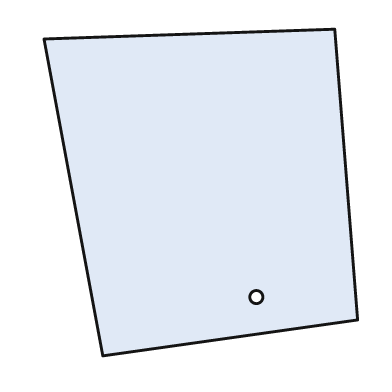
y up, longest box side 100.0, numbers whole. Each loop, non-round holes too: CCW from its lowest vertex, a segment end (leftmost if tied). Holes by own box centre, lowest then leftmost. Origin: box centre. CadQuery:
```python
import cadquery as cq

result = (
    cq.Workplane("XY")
    .moveTo(-30.0, -50.0)
    .lineTo(48.0, -39.0)
    .lineTo(41.0, 50.0)
    .lineTo(-48.0, 47.0)
    .close()
    .moveTo(17.0, -32.0)
    .circle(2.0)
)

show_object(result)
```